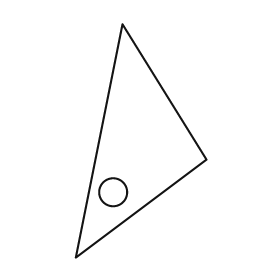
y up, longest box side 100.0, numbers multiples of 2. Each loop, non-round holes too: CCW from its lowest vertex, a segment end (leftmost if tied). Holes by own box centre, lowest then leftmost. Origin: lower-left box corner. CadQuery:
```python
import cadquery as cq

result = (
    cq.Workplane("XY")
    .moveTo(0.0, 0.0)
    .lineTo(56.0, 42.0)
    .lineTo(20.0, 100.0)
    .close()
    .moveTo(16.0, 28.0)
    .circle(6.0)
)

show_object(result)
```